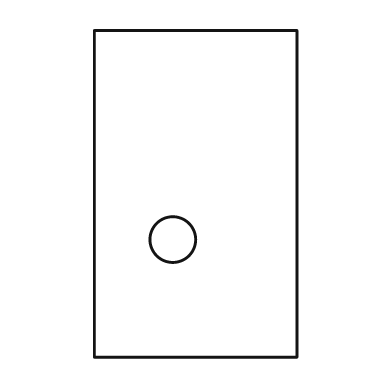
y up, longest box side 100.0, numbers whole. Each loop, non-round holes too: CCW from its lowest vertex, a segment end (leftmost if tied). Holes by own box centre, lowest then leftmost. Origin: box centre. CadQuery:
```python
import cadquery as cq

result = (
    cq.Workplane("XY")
    .moveTo(-31.0, -50.0)
    .lineTo(31.0, -50.0)
    .lineTo(31.0, 50.0)
    .lineTo(-31.0, 50.0)
    .close()
    .moveTo(-7.0, -14.0)
    .circle(7.0)
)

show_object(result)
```